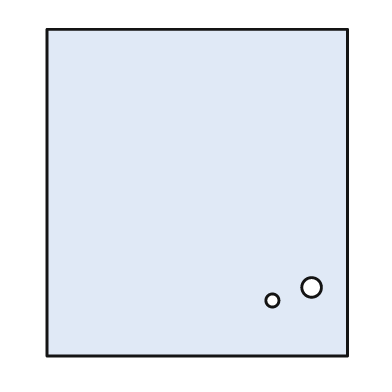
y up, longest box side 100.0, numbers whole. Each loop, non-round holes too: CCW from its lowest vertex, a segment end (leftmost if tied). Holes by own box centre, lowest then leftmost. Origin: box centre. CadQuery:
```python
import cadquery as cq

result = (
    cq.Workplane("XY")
    .moveTo(-46.0, -50.0)
    .lineTo(46.0, -50.0)
    .lineTo(46.0, 50.0)
    .lineTo(-46.0, 50.0)
    .close()
    .moveTo(23.0, -33.0)
    .circle(2.0)
    .moveTo(35.0, -29.0)
    .circle(3.0)
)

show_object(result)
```